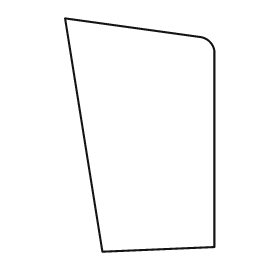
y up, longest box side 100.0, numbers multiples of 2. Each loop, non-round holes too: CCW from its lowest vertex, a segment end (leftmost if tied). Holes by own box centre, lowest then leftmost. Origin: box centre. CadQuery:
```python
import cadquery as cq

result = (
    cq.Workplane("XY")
    .moveTo(-16.0, -50.0)
    .lineTo(32.0, -48.0)
    .lineTo(32.0, 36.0)
    .threePointArc((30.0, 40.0), (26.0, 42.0))
    .lineTo(-32.0, 50.0)
    .close()
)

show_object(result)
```